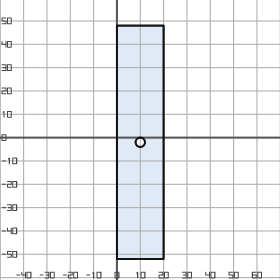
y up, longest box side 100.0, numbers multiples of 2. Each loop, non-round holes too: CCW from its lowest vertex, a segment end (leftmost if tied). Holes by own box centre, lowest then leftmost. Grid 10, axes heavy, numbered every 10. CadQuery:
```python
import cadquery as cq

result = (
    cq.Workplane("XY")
    .moveTo(0.0, -52.0)
    .lineTo(20.0, -52.0)
    .lineTo(20.0, 48.0)
    .lineTo(0.0, 48.0)
    .close()
    .moveTo(10.0, -2.0)
    .circle(2.0)
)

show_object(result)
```